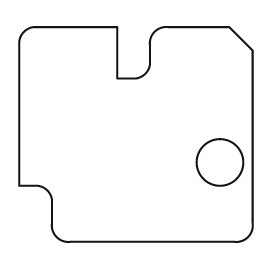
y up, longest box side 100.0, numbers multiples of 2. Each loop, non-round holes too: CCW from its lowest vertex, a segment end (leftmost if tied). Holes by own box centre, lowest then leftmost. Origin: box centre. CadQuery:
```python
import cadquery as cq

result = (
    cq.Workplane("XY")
    .moveTo(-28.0, -46.0)
    .lineTo(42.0, -46.0)
    .threePointArc((48.0, -44.0), (50.0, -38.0))
    .lineTo(50.0, 36.0)
    .lineTo(40.0, 46.0)
    .lineTo(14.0, 46.0)
    .threePointArc((8.0, 44.0), (6.0, 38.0))
    .lineTo(6.0, 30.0)
    .threePointArc((4.0, 26.0), (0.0, 24.0))
    .lineTo(-8.0, 24.0)
    .lineTo(-8.0, 46.0)
    .lineTo(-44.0, 46.0)
    .threePointArc((-48.0, 44.0), (-50.0, 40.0))
    .lineTo(-50.0, -22.0)
    .lineTo(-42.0, -22.0)
    .threePointArc((-38.0, -24.0), (-36.0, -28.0))
    .lineTo(-36.0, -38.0)
    .threePointArc((-34.0, -44.0), (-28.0, -46.0))
    .close()
    .moveTo(36.0, -12.0)
    .circle(10.0)
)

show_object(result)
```